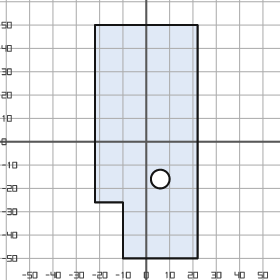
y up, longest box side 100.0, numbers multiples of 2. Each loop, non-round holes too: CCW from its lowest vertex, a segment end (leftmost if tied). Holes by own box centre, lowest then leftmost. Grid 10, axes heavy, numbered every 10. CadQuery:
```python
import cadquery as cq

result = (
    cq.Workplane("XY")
    .moveTo(-10.0, -50.0)
    .lineTo(22.0, -50.0)
    .lineTo(22.0, 50.0)
    .lineTo(-22.0, 50.0)
    .lineTo(-22.0, -26.0)
    .lineTo(-10.0, -26.0)
    .close()
    .moveTo(6.0, -16.0)
    .circle(4.0)
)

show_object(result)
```